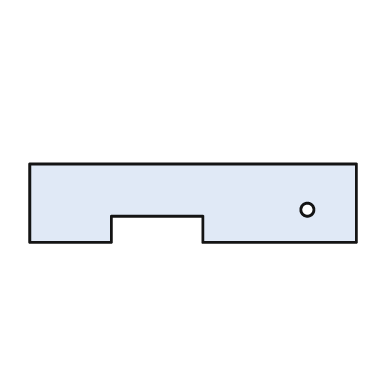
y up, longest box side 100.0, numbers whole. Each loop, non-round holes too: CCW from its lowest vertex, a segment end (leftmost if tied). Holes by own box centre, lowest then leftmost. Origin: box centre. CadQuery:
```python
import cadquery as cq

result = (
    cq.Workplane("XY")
    .moveTo(-50.0, -12.0)
    .lineTo(-25.0, -12.0)
    .lineTo(-25.0, -4.0)
    .lineTo(3.0, -4.0)
    .lineTo(3.0, -12.0)
    .lineTo(50.0, -12.0)
    .lineTo(50.0, 12.0)
    .lineTo(-50.0, 12.0)
    .close()
    .moveTo(35.0, -2.0)
    .circle(2.0)
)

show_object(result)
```